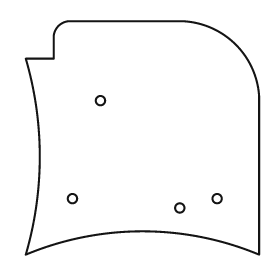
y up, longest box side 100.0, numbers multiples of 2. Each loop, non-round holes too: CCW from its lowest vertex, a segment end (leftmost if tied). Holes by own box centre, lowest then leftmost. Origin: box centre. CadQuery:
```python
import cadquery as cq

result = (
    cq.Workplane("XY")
    .moveTo(-50.0, -50.0)
    .threePointArc((0.0, -40.0), (50.0, -50.0))
    .lineTo(50.0, 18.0)
    .threePointArc((40.0, 40.0), (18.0, 50.0))
    .lineTo(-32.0, 50.0)
    .threePointArc((-36.0, 48.0), (-38.0, 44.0))
    .lineTo(-38.0, 34.0)
    .lineTo(-50.0, 34.0)
    .threePointArc((-44.0, -8.0), (-50.0, -50.0))
    .close()
    .moveTo(16.0, -30.0)
    .circle(2.0)
    .moveTo(-30.0, -26.0)
    .circle(2.0)
    .moveTo(32.0, -26.0)
    .circle(2.0)
    .moveTo(-18.0, 16.0)
    .circle(2.0)
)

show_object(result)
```